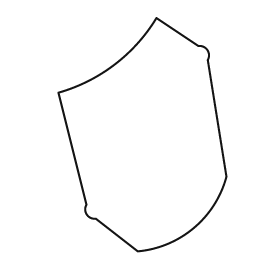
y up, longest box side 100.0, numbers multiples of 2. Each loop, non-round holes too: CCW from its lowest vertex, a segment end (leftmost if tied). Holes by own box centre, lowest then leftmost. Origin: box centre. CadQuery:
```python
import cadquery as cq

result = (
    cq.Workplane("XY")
    .moveTo(-2.0, -50.0)
    .threePointArc((22.0, -40.0), (36.0, -18.0))
    .lineTo(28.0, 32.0)
    .threePointArc((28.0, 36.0), (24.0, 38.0))
    .lineTo(6.0, 50.0)
    .threePointArc((-12.0, 30.0), (-36.0, 18.0))
    .lineTo(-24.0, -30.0)
    .threePointArc((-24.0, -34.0), (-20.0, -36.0))
    .close()
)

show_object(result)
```